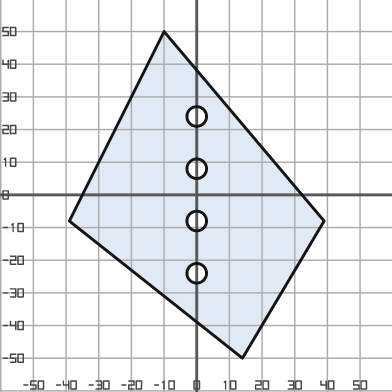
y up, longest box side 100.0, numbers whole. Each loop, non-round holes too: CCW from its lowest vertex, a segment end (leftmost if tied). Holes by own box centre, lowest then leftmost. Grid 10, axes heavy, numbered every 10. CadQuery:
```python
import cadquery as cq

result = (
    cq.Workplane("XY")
    .moveTo(14.0, -50.0)
    .lineTo(39.0, -8.0)
    .lineTo(-10.0, 50.0)
    .lineTo(-39.0, -8.0)
    .close()
    .moveTo(0.0, -24.0)
    .circle(3.0)
    .moveTo(0.0, -8.0)
    .circle(3.0)
    .moveTo(0.0, 8.0)
    .circle(3.0)
    .moveTo(0.0, 24.0)
    .circle(3.0)
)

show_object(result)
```